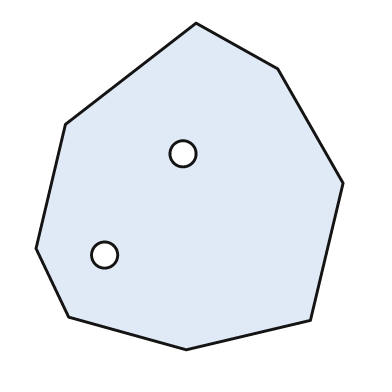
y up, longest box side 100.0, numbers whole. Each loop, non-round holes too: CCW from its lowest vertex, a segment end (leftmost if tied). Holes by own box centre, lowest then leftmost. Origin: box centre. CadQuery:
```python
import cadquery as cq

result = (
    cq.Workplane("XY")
    .moveTo(-1.0, -50.0)
    .lineTo(37.0, -41.0)
    .lineTo(47.0, 1.0)
    .lineTo(27.0, 36.0)
    .lineTo(2.0, 50.0)
    .lineTo(-38.0, 19.0)
    .lineTo(-47.0, -19.0)
    .lineTo(-37.0, -40.0)
    .close()
    .moveTo(-26.0, -21.0)
    .circle(4.0)
    .moveTo(-2.0, 10.0)
    .circle(4.0)
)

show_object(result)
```